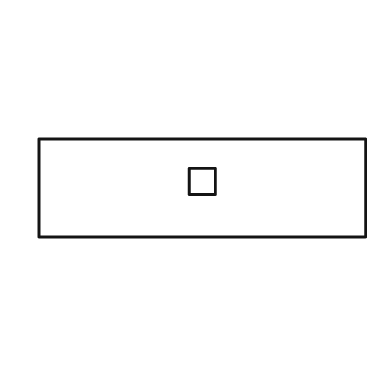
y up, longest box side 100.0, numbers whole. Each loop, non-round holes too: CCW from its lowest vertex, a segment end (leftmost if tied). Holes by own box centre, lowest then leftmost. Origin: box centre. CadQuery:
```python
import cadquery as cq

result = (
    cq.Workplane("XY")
    .moveTo(-50.0, -15.0)
    .lineTo(50.0, -15.0)
    .lineTo(50.0, 15.0)
    .lineTo(-50.0, 15.0)
    .close()
    .moveTo(-4.0, -2.0)
    .lineTo(4.0, -2.0)
    .lineTo(4.0, 6.0)
    .lineTo(-4.0, 6.0)
    .close()
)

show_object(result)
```